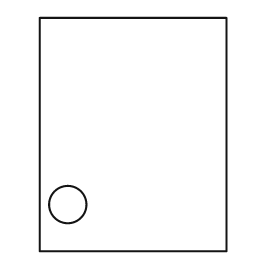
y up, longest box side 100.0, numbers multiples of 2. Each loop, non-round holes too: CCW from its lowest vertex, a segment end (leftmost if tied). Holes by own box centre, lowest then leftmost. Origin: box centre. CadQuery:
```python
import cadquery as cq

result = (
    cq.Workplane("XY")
    .moveTo(-40.0, -50.0)
    .lineTo(40.0, -50.0)
    .lineTo(40.0, 50.0)
    .lineTo(-40.0, 50.0)
    .close()
    .moveTo(-28.0, -30.0)
    .circle(8.0)
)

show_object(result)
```